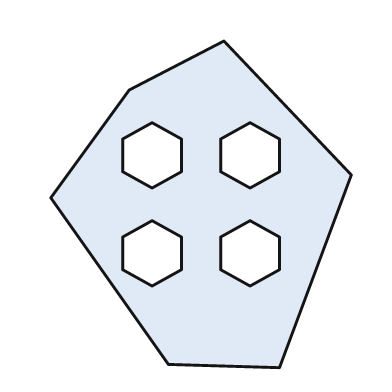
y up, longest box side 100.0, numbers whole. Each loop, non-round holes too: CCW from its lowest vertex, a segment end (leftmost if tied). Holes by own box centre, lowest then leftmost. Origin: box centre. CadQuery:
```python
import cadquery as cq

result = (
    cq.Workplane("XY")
    .moveTo(24.0, -50.0)
    .lineTo(46.0, 9.0)
    .lineTo(7.0, 50.0)
    .lineTo(-22.0, 35.0)
    .lineTo(-46.0, 2.0)
    .lineTo(-10.0, -49.0)
    .close()
    .moveTo(-15.0, -25.0)
    .lineTo(-6.0, -20.0)
    .lineTo(-6.0, -10.0)
    .lineTo(-15.0, -5.0)
    .lineTo(-24.0, -10.0)
    .lineTo(-24.0, -20.0)
    .close()
    .moveTo(15.0, -25.0)
    .lineTo(24.0, -20.0)
    .lineTo(24.0, -10.0)
    .lineTo(15.0, -5.0)
    .lineTo(6.0, -10.0)
    .lineTo(6.0, -20.0)
    .close()
    .moveTo(-15.0, 5.0)
    .lineTo(-6.0, 10.0)
    .lineTo(-6.0, 20.0)
    .lineTo(-15.0, 25.0)
    .lineTo(-24.0, 20.0)
    .lineTo(-24.0, 10.0)
    .close()
    .moveTo(15.0, 5.0)
    .lineTo(24.0, 10.0)
    .lineTo(24.0, 20.0)
    .lineTo(15.0, 25.0)
    .lineTo(6.0, 20.0)
    .lineTo(6.0, 10.0)
    .close()
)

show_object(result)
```